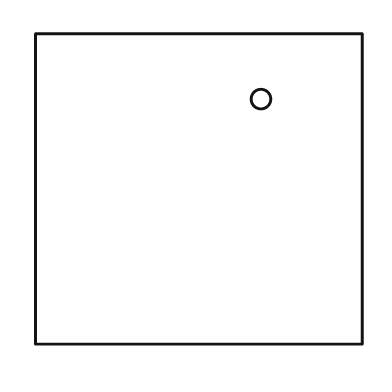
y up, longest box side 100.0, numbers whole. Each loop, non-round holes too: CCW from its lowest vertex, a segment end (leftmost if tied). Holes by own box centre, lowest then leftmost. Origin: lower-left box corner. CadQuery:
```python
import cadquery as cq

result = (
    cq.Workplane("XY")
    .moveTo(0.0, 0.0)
    .lineTo(100.0, 0.0)
    .lineTo(100.0, 95.0)
    .lineTo(0.0, 95.0)
    .close()
    .moveTo(69.0, 75.0)
    .circle(3.0)
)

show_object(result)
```